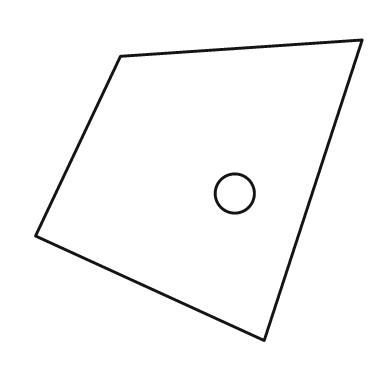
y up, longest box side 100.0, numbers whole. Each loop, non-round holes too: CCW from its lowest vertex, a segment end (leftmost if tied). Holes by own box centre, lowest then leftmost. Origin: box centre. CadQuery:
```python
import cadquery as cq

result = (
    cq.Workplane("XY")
    .moveTo(20.0, -46.0)
    .lineTo(50.0, 46.0)
    .lineTo(-24.0, 41.0)
    .lineTo(-50.0, -14.0)
    .close()
    .moveTo(11.0, -1.0)
    .circle(6.0)
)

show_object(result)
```